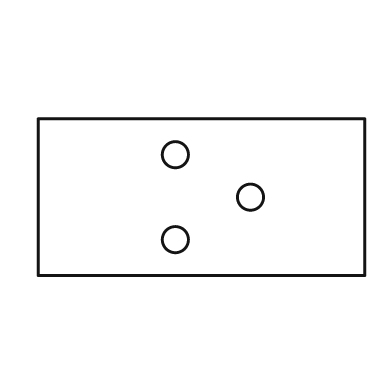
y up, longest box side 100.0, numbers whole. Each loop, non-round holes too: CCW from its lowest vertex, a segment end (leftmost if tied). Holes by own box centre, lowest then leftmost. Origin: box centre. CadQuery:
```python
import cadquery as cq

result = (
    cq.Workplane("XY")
    .moveTo(-50.0, -24.0)
    .lineTo(50.0, -24.0)
    .lineTo(50.0, 24.0)
    .lineTo(-50.0, 24.0)
    .close()
    .moveTo(-8.0, -13.0)
    .circle(4.0)
    .moveTo(15.0, 0.0)
    .circle(4.0)
    .moveTo(-8.0, 13.0)
    .circle(4.0)
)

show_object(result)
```